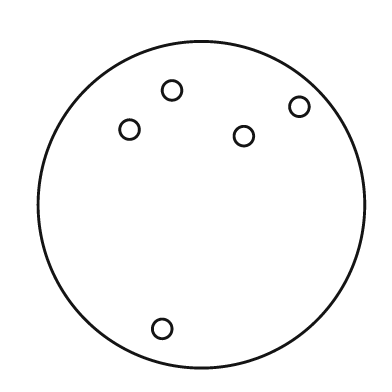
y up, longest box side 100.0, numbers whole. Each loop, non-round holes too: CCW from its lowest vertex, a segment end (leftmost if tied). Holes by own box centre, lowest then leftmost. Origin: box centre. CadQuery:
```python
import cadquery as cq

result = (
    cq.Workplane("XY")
    .moveTo(0.0, 0.0)
    .circle(50.0)
    .moveTo(-12.0, -38.0)
    .circle(3.0)
    .moveTo(13.0, 21.0)
    .circle(3.0)
    .moveTo(-22.0, 23.0)
    .circle(3.0)
    .moveTo(30.0, 30.0)
    .circle(3.0)
    .moveTo(-9.0, 35.0)
    .circle(3.0)
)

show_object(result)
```